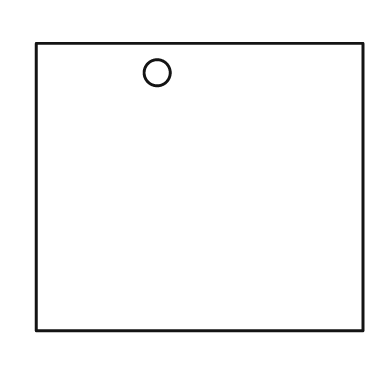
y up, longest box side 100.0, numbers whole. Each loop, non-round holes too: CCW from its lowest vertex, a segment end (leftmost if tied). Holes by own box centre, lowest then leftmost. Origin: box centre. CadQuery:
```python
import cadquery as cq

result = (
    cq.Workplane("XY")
    .moveTo(-50.0, -44.0)
    .lineTo(50.0, -44.0)
    .lineTo(50.0, 44.0)
    .lineTo(-50.0, 44.0)
    .close()
    .moveTo(-13.0, 35.0)
    .circle(4.0)
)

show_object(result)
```